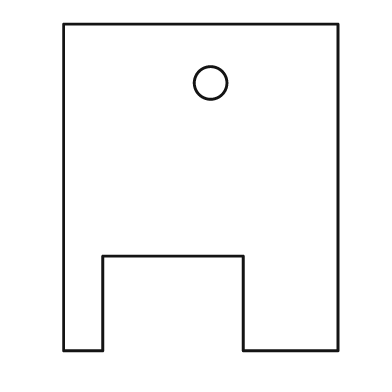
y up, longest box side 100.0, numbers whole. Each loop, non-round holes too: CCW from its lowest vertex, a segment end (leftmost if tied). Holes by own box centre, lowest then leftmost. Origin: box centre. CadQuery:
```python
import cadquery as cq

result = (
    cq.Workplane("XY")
    .moveTo(-42.0, -50.0)
    .lineTo(-30.0, -50.0)
    .lineTo(-30.0, -21.0)
    .lineTo(13.0, -21.0)
    .lineTo(13.0, -50.0)
    .lineTo(42.0, -50.0)
    .lineTo(42.0, 50.0)
    .lineTo(-42.0, 50.0)
    .close()
    .moveTo(3.0, 32.0)
    .circle(5.0)
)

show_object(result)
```